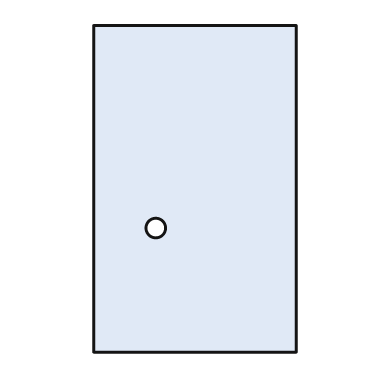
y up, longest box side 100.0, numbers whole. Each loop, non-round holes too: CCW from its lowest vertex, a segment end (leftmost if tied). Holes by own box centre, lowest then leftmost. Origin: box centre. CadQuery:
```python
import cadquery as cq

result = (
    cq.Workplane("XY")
    .moveTo(-31.0, -50.0)
    .lineTo(31.0, -50.0)
    .lineTo(31.0, 50.0)
    .lineTo(-31.0, 50.0)
    .close()
    .moveTo(-12.0, -12.0)
    .circle(3.0)
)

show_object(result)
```